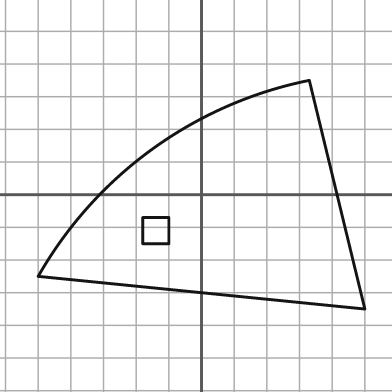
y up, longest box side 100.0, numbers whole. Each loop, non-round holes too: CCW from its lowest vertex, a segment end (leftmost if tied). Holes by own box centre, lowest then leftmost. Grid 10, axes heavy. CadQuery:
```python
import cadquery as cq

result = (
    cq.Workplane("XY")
    .moveTo(50.0, -35.0)
    .lineTo(33.0, 35.0)
    .threePointArc((-15.0, 14.0), (-50.0, -25.0))
    .close()
    .moveTo(-18.0, -15.0)
    .lineTo(-10.0, -15.0)
    .lineTo(-10.0, -7.0)
    .lineTo(-18.0, -7.0)
    .close()
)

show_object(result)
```